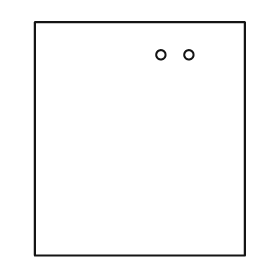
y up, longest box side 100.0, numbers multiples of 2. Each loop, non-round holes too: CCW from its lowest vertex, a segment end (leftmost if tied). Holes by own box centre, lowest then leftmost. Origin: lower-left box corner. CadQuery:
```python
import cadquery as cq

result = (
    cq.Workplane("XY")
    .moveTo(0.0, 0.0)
    .lineTo(90.0, 0.0)
    .lineTo(90.0, 100.0)
    .lineTo(0.0, 100.0)
    .close()
    .moveTo(54.0, 86.0)
    .circle(2.0)
    .moveTo(66.0, 86.0)
    .circle(2.0)
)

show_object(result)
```